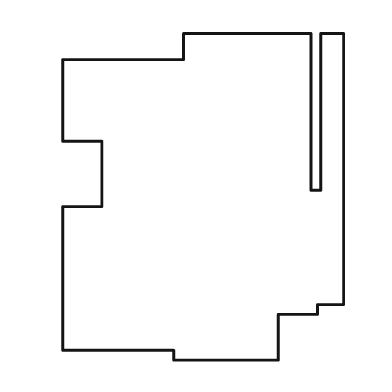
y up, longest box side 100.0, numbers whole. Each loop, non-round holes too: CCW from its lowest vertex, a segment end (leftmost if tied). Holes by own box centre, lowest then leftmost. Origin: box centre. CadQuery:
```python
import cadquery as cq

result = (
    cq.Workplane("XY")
    .moveTo(-9.0, -50.0)
    .lineTo(23.0, -50.0)
    .lineTo(23.0, -36.0)
    .lineTo(35.0, -36.0)
    .lineTo(35.0, -33.0)
    .lineTo(43.0, -33.0)
    .lineTo(43.0, 50.0)
    .lineTo(36.0, 50.0)
    .lineTo(36.0, 2.0)
    .lineTo(33.0, 2.0)
    .lineTo(33.0, 50.0)
    .lineTo(-6.0, 50.0)
    .lineTo(-6.0, 42.0)
    .lineTo(-43.0, 42.0)
    .lineTo(-43.0, 17.0)
    .lineTo(-31.0, 17.0)
    .lineTo(-31.0, -3.0)
    .lineTo(-43.0, -3.0)
    .lineTo(-43.0, -47.0)
    .lineTo(-9.0, -47.0)
    .close()
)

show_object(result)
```